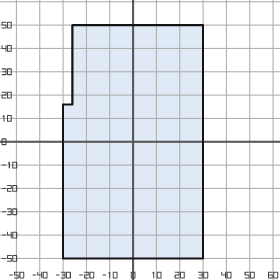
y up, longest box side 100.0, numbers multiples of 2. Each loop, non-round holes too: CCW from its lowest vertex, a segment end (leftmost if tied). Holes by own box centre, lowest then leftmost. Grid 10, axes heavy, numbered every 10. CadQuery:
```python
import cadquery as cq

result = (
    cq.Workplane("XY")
    .moveTo(-30.0, -50.0)
    .lineTo(30.0, -50.0)
    .lineTo(30.0, 50.0)
    .lineTo(-26.0, 50.0)
    .lineTo(-26.0, 16.0)
    .lineTo(-30.0, 16.0)
    .close()
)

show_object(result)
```